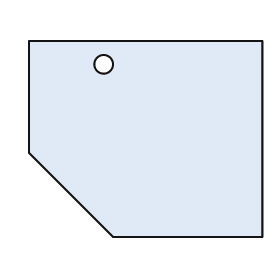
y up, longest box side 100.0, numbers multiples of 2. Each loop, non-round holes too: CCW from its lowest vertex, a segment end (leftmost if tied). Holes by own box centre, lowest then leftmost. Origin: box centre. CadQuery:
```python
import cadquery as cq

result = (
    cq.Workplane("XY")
    .moveTo(-14.0, -42.0)
    .lineTo(50.0, -42.0)
    .lineTo(50.0, 42.0)
    .lineTo(-50.0, 42.0)
    .lineTo(-50.0, -6.0)
    .close()
    .moveTo(-18.0, 32.0)
    .circle(4.0)
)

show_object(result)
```